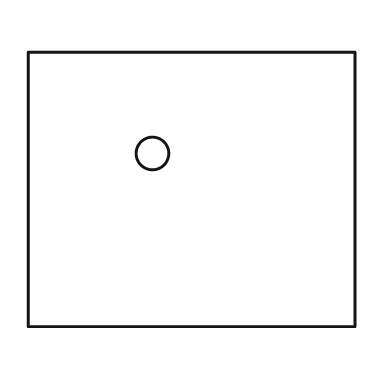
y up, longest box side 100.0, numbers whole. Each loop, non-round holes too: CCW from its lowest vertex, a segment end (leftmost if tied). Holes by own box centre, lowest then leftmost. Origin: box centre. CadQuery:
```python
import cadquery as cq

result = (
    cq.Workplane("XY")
    .moveTo(-50.0, -42.0)
    .lineTo(50.0, -42.0)
    .lineTo(50.0, 42.0)
    .lineTo(-50.0, 42.0)
    .close()
    .moveTo(-12.0, 11.0)
    .circle(5.0)
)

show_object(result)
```